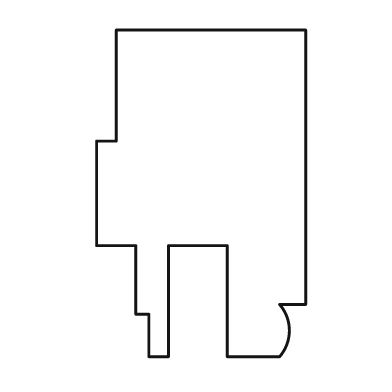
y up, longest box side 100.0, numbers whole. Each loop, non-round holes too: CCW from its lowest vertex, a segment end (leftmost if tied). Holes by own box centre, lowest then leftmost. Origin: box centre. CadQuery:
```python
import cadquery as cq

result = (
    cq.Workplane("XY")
    .moveTo(-16.0, -50.0)
    .lineTo(-10.0, -50.0)
    .lineTo(-10.0, -16.0)
    .lineTo(8.0, -16.0)
    .lineTo(8.0, -50.0)
    .lineTo(24.0, -50.0)
    .threePointArc((27.0, -42.0), (24.0, -34.0))
    .lineTo(32.0, -34.0)
    .lineTo(32.0, 50.0)
    .lineTo(-26.0, 50.0)
    .lineTo(-26.0, 16.0)
    .lineTo(-32.0, 16.0)
    .lineTo(-32.0, -16.0)
    .lineTo(-20.0, -16.0)
    .lineTo(-20.0, -37.0)
    .lineTo(-16.0, -37.0)
    .close()
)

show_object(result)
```